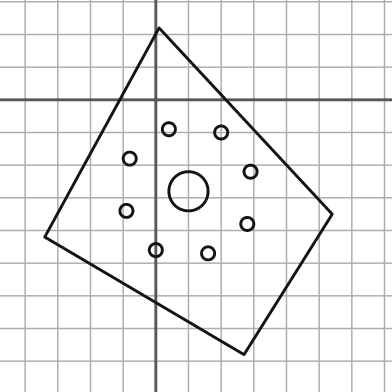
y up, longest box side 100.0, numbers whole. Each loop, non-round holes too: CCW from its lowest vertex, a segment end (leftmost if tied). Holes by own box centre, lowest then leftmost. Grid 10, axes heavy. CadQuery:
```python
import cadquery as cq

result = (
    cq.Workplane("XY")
    .moveTo(27.0, -78.0)
    .lineTo(54.0, -35.0)
    .lineTo(1.0, 22.0)
    .lineTo(-34.0, -42.0)
    .close()
    .moveTo(16.0, -47.0)
    .circle(2.0)
    .moveTo(0.0, -46.0)
    .circle(2.0)
    .moveTo(28.0, -38.0)
    .circle(2.0)
    .moveTo(-9.0, -34.0)
    .circle(2.0)
    .moveTo(10.0, -28.0)
    .circle(6.0)
    .moveTo(29.0, -22.0)
    .circle(2.0)
    .moveTo(-8.0, -18.0)
    .circle(2.0)
    .moveTo(20.0, -10.0)
    .circle(2.0)
    .moveTo(4.0, -9.0)
    .circle(2.0)
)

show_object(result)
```